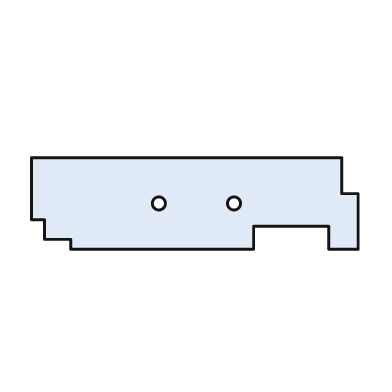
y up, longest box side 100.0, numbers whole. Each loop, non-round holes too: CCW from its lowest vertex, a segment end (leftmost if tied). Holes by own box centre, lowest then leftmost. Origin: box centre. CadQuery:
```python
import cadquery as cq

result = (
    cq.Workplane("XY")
    .moveTo(-38.0, -14.0)
    .lineTo(18.0, -14.0)
    .lineTo(18.0, -7.0)
    .lineTo(41.0, -7.0)
    .lineTo(41.0, -14.0)
    .lineTo(50.0, -14.0)
    .lineTo(50.0, 3.0)
    .lineTo(45.0, 3.0)
    .lineTo(45.0, 14.0)
    .lineTo(-50.0, 14.0)
    .lineTo(-50.0, -5.0)
    .lineTo(-46.0, -5.0)
    .lineTo(-46.0, -11.0)
    .lineTo(-38.0, -11.0)
    .close()
    .moveTo(-11.0, 0.0)
    .circle(2.0)
    .moveTo(12.0, 0.0)
    .circle(2.0)
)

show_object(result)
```